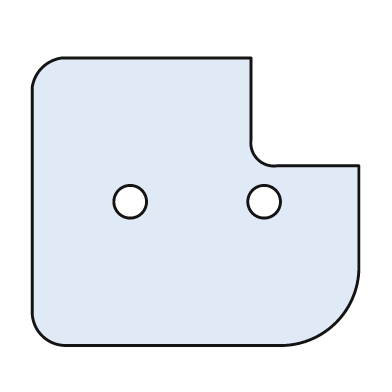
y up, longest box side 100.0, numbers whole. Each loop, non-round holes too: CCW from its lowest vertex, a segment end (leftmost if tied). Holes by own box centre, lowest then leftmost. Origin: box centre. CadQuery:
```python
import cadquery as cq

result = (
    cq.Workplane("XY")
    .moveTo(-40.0, -44.0)
    .lineTo(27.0, -44.0)
    .threePointArc((43.0, -37.0), (50.0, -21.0))
    .lineTo(50.0, 11.0)
    .lineTo(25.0, 11.0)
    .threePointArc((19.0, 13.0), (17.0, 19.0))
    .lineTo(17.0, 44.0)
    .lineTo(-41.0, 44.0)
    .threePointArc((-47.0, 41.0), (-50.0, 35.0))
    .lineTo(-50.0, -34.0)
    .threePointArc((-47.0, -41.0), (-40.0, -44.0))
    .close()
    .moveTo(-20.0, 0.0)
    .circle(5.0)
    .moveTo(21.0, 0.0)
    .circle(5.0)
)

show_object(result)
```